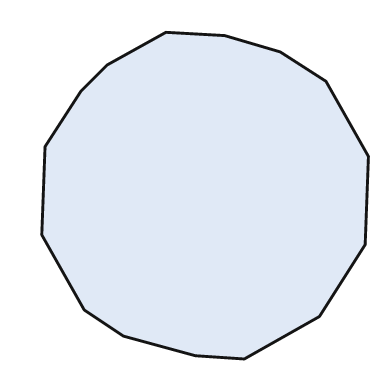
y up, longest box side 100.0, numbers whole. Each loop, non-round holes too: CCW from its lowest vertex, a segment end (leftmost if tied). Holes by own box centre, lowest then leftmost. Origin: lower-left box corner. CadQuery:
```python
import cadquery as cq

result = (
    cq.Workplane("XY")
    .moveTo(62.0, 0.0)
    .lineTo(85.0, 13.0)
    .lineTo(99.0, 35.0)
    .lineTo(100.0, 62.0)
    .lineTo(87.0, 85.0)
    .lineTo(73.0, 94.0)
    .lineTo(56.0, 99.0)
    .lineTo(38.0, 100.0)
    .lineTo(20.0, 90.0)
    .lineTo(12.0, 82.0)
    .lineTo(1.0, 65.0)
    .lineTo(0.0, 38.0)
    .lineTo(13.0, 15.0)
    .lineTo(25.0, 7.0)
    .lineTo(47.0, 1.0)
    .close()
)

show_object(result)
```